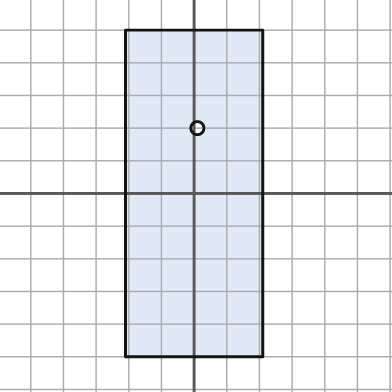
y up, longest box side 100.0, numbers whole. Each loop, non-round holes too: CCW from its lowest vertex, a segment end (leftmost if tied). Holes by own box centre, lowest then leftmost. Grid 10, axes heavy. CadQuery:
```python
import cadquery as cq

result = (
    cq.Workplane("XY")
    .moveTo(-21.0, -50.0)
    .lineTo(21.0, -50.0)
    .lineTo(21.0, 50.0)
    .lineTo(-21.0, 50.0)
    .close()
    .moveTo(1.0, 20.0)
    .circle(2.0)
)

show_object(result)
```